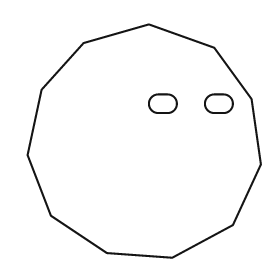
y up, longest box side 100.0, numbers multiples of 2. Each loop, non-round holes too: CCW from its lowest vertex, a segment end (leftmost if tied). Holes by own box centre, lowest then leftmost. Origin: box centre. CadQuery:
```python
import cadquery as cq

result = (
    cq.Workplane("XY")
    .moveTo(12.0, -50.0)
    .lineTo(38.0, -36.0)
    .lineTo(50.0, -10.0)
    .lineTo(46.0, 18.0)
    .lineTo(30.0, 40.0)
    .lineTo(2.0, 50.0)
    .lineTo(-26.0, 42.0)
    .lineTo(-44.0, 22.0)
    .lineTo(-50.0, -6.0)
    .lineTo(-40.0, -32.0)
    .lineTo(-16.0, -48.0)
    .close()
    .moveTo(6.0, 12.0)
    .lineTo(10.0, 12.0)
    .threePointArc((14.0, 16.0), (10.0, 20.0))
    .lineTo(6.0, 20.0)
    .threePointArc((2.0, 16.0), (6.0, 12.0))
    .close()
    .moveTo(30.0, 12.0)
    .lineTo(34.0, 12.0)
    .threePointArc((38.0, 16.0), (34.0, 20.0))
    .lineTo(30.0, 20.0)
    .threePointArc((26.0, 16.0), (30.0, 12.0))
    .close()
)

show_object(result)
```